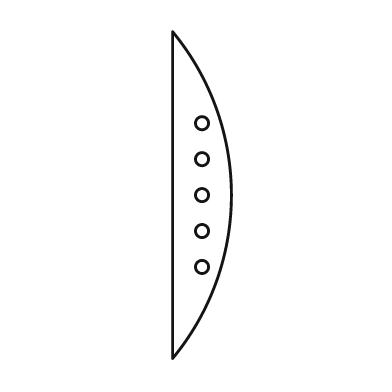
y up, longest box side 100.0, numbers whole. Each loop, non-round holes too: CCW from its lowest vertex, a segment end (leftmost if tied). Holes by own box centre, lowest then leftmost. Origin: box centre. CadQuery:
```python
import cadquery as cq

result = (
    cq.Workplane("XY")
    .moveTo(-9.0, -50.0)
    .threePointArc((9.0, 0.0), (-9.0, 50.0))
    .close()
    .moveTo(0.0, -22.0)
    .circle(2.0)
    .moveTo(0.0, -11.0)
    .circle(2.0)
    .moveTo(0.0, 0.0)
    .circle(2.0)
    .moveTo(0.0, 11.0)
    .circle(2.0)
    .moveTo(0.0, 22.0)
    .circle(2.0)
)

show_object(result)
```